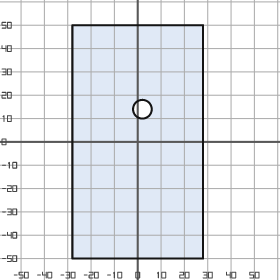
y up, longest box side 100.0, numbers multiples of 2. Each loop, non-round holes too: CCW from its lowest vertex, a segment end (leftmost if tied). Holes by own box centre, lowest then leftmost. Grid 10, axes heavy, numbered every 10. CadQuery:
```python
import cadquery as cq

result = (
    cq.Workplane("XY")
    .moveTo(-28.0, -50.0)
    .lineTo(28.0, -50.0)
    .lineTo(28.0, 50.0)
    .lineTo(-28.0, 50.0)
    .close()
    .moveTo(2.0, 14.0)
    .circle(4.0)
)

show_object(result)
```